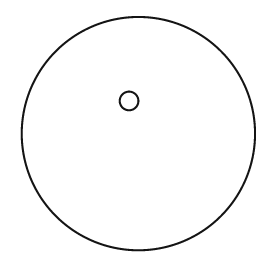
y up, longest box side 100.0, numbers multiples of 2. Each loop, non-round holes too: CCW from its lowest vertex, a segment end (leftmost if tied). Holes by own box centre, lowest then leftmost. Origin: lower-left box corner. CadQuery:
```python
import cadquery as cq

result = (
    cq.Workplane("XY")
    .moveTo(50.0, 50.0)
    .circle(50.0)
    .moveTo(46.0, 64.0)
    .circle(4.0)
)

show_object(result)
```